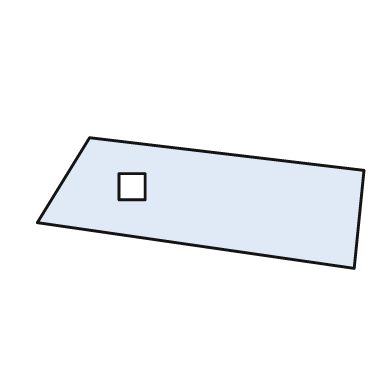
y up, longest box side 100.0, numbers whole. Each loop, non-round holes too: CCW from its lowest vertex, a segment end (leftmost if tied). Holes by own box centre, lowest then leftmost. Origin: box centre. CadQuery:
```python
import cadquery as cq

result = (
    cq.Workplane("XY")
    .moveTo(47.0, -20.0)
    .lineTo(50.0, 10.0)
    .lineTo(-34.0, 20.0)
    .lineTo(-50.0, -6.0)
    .close()
    .moveTo(-25.0, 1.0)
    .lineTo(-17.0, 1.0)
    .lineTo(-17.0, 9.0)
    .lineTo(-25.0, 9.0)
    .close()
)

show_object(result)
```